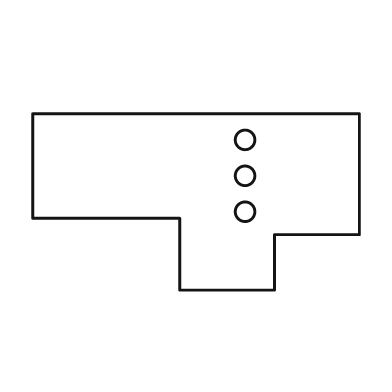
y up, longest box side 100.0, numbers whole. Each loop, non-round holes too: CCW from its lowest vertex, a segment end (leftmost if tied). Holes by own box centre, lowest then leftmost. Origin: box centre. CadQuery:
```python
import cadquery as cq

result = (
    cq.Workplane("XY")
    .moveTo(-5.0, -27.0)
    .lineTo(24.0, -27.0)
    .lineTo(24.0, -10.0)
    .lineTo(50.0, -10.0)
    .lineTo(50.0, 27.0)
    .lineTo(-50.0, 27.0)
    .lineTo(-50.0, -5.0)
    .lineTo(-5.0, -5.0)
    .close()
    .moveTo(15.0, -3.0)
    .circle(3.0)
    .moveTo(15.0, 8.0)
    .circle(3.0)
    .moveTo(15.0, 19.0)
    .circle(3.0)
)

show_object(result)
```